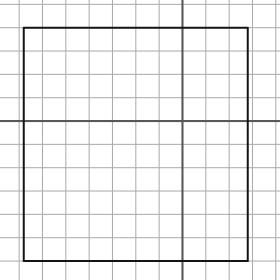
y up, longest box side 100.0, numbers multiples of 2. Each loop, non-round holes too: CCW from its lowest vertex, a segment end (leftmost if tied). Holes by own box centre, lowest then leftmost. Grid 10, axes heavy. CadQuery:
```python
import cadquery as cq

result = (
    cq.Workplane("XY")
    .moveTo(-68.0, -60.0)
    .lineTo(28.0, -60.0)
    .lineTo(28.0, 40.0)
    .lineTo(-68.0, 40.0)
    .close()
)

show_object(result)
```